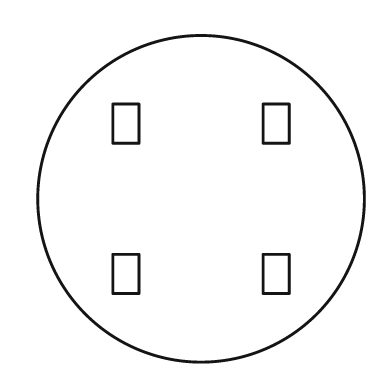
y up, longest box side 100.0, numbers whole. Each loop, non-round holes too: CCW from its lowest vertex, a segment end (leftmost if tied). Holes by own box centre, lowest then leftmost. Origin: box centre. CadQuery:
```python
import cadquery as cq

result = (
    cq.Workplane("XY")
    .moveTo(0.0, 0.0)
    .circle(50.0)
    .moveTo(-27.0, -29.0)
    .lineTo(-19.0, -29.0)
    .lineTo(-19.0, -17.0)
    .lineTo(-27.0, -17.0)
    .close()
    .moveTo(19.0, -29.0)
    .lineTo(27.0, -29.0)
    .lineTo(27.0, -17.0)
    .lineTo(19.0, -17.0)
    .close()
    .moveTo(-27.0, 17.0)
    .lineTo(-19.0, 17.0)
    .lineTo(-19.0, 29.0)
    .lineTo(-27.0, 29.0)
    .close()
    .moveTo(19.0, 17.0)
    .lineTo(27.0, 17.0)
    .lineTo(27.0, 29.0)
    .lineTo(19.0, 29.0)
    .close()
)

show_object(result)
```